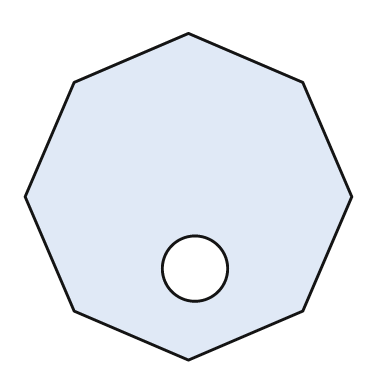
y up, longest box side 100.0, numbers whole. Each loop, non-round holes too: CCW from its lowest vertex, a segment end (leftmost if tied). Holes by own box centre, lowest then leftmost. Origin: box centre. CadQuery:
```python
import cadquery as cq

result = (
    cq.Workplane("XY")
    .moveTo(0.0, -50.0)
    .lineTo(35.0, -35.0)
    .lineTo(50.0, 0.0)
    .lineTo(35.0, 35.0)
    .lineTo(0.0, 50.0)
    .lineTo(-35.0, 35.0)
    .lineTo(-50.0, 0.0)
    .lineTo(-35.0, -35.0)
    .close()
    .moveTo(2.0, -22.0)
    .circle(10.0)
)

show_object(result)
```